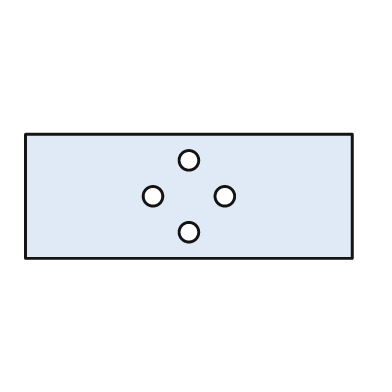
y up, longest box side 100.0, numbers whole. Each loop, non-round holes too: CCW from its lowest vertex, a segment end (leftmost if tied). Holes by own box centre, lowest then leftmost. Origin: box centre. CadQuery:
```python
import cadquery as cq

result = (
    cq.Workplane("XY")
    .moveTo(-50.0, -19.0)
    .lineTo(50.0, -19.0)
    .lineTo(50.0, 19.0)
    .lineTo(-50.0, 19.0)
    .close()
    .moveTo(0.0, -11.0)
    .circle(3.0)
    .moveTo(-11.0, 0.0)
    .circle(3.0)
    .moveTo(11.0, 0.0)
    .circle(3.0)
    .moveTo(0.0, 11.0)
    .circle(3.0)
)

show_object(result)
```